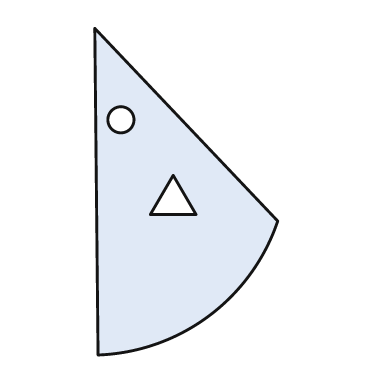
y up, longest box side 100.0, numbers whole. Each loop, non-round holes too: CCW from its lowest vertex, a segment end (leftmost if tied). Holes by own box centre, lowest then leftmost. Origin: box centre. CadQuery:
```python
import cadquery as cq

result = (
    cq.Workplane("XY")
    .moveTo(-27.0, -50.0)
    .threePointArc((7.0, -38.0), (28.0, -9.0))
    .lineTo(-28.0, 50.0)
    .close()
    .moveTo(-11.0, -7.0)
    .lineTo(3.0, -7.0)
    .lineTo(-4.0, 5.0)
    .close()
    .moveTo(-20.0, 22.0)
    .circle(4.0)
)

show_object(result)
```